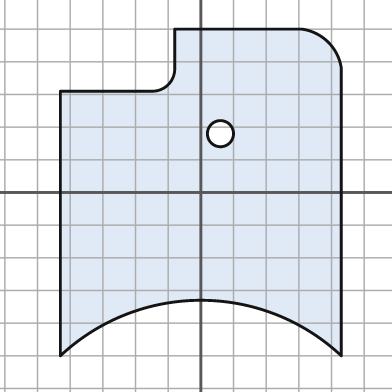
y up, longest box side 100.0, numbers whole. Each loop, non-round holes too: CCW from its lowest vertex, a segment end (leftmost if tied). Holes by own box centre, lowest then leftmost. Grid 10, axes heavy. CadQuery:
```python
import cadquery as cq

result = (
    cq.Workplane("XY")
    .moveTo(-43.0, -50.0)
    .threePointArc((0.0, -33.0), (43.0, -50.0))
    .lineTo(43.0, 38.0)
    .threePointArc((39.0, 46.0), (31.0, 50.0))
    .lineTo(-8.0, 50.0)
    .lineTo(-8.0, 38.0)
    .threePointArc((-10.0, 33.0), (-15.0, 31.0))
    .lineTo(-43.0, 31.0)
    .close()
    .moveTo(6.0, 18.0)
    .circle(4.0)
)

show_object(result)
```